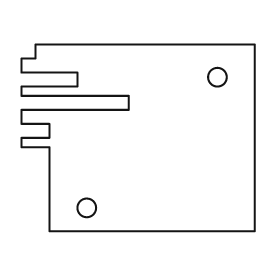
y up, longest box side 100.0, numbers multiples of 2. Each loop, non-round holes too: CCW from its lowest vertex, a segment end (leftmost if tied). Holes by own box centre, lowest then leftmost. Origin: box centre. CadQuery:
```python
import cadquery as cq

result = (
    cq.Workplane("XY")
    .moveTo(-38.0, -40.0)
    .lineTo(50.0, -40.0)
    .lineTo(50.0, 40.0)
    .lineTo(-44.0, 40.0)
    .lineTo(-44.0, 34.0)
    .lineTo(-50.0, 34.0)
    .lineTo(-50.0, 28.0)
    .lineTo(-26.0, 28.0)
    .lineTo(-26.0, 22.0)
    .lineTo(-50.0, 22.0)
    .lineTo(-50.0, 18.0)
    .lineTo(-4.0, 18.0)
    .lineTo(-4.0, 12.0)
    .lineTo(-50.0, 12.0)
    .lineTo(-50.0, 6.0)
    .lineTo(-38.0, 6.0)
    .lineTo(-38.0, 0.0)
    .lineTo(-50.0, 0.0)
    .lineTo(-50.0, -4.0)
    .lineTo(-38.0, -4.0)
    .close()
    .moveTo(-22.0, -30.0)
    .circle(4.0)
    .moveTo(34.0, 26.0)
    .circle(4.0)
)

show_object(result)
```